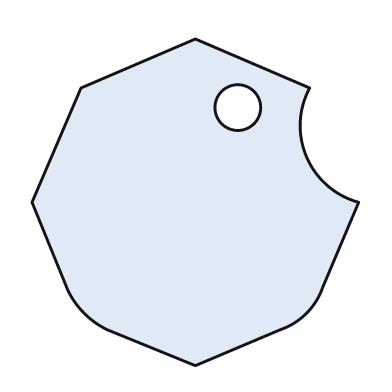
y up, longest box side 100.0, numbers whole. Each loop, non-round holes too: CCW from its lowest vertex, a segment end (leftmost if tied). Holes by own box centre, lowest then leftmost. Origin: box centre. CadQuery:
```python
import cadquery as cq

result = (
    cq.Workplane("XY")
    .moveTo(0.0, -50.0)
    .lineTo(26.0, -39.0)
    .threePointArc((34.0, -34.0), (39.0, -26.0))
    .lineTo(50.0, 0.0)
    .threePointArc((34.0, 14.0), (35.0, 35.0))
    .lineTo(0.0, 50.0)
    .lineTo(-35.0, 35.0)
    .lineTo(-50.0, 0.0)
    .lineTo(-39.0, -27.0)
    .threePointArc((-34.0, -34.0), (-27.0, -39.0))
    .close()
    .moveTo(13.0, 29.0)
    .circle(7.0)
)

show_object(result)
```